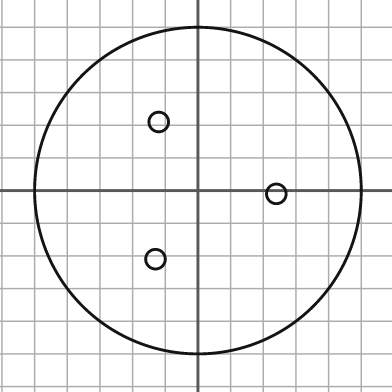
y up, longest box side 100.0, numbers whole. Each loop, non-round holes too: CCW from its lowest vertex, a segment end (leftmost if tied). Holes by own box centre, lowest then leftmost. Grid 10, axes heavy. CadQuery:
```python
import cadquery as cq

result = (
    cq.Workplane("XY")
    .moveTo(0.0, 0.0)
    .circle(50.0)
    .moveTo(-13.0, -21.0)
    .circle(3.0)
    .moveTo(24.0, -1.0)
    .circle(3.0)
    .moveTo(-12.0, 21.0)
    .circle(3.0)
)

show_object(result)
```